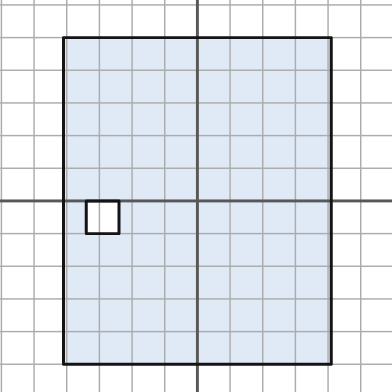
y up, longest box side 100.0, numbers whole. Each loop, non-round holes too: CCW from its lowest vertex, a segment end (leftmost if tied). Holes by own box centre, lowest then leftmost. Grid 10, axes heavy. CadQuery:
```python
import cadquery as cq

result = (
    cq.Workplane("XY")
    .moveTo(-41.0, -50.0)
    .lineTo(41.0, -50.0)
    .lineTo(41.0, 50.0)
    .lineTo(-41.0, 50.0)
    .close()
    .moveTo(-34.0, -10.0)
    .lineTo(-24.0, -10.0)
    .lineTo(-24.0, 0.0)
    .lineTo(-34.0, 0.0)
    .close()
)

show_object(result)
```